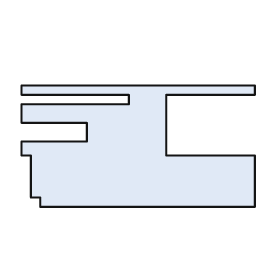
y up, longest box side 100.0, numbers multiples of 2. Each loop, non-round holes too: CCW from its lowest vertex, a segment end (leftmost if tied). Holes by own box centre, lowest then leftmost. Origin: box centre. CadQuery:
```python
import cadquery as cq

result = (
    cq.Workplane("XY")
    .moveTo(-42.0, -26.0)
    .lineTo(50.0, -26.0)
    .lineTo(50.0, -4.0)
    .lineTo(12.0, -4.0)
    .lineTo(12.0, 22.0)
    .lineTo(50.0, 22.0)
    .lineTo(50.0, 26.0)
    .lineTo(-50.0, 26.0)
    .lineTo(-50.0, 22.0)
    .lineTo(-4.0, 22.0)
    .lineTo(-4.0, 18.0)
    .lineTo(-50.0, 18.0)
    .lineTo(-50.0, 10.0)
    .lineTo(-22.0, 10.0)
    .lineTo(-22.0, 2.0)
    .lineTo(-50.0, 2.0)
    .lineTo(-50.0, -4.0)
    .lineTo(-46.0, -4.0)
    .lineTo(-46.0, -22.0)
    .lineTo(-42.0, -22.0)
    .close()
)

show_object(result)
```